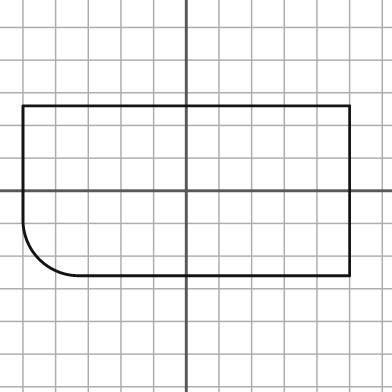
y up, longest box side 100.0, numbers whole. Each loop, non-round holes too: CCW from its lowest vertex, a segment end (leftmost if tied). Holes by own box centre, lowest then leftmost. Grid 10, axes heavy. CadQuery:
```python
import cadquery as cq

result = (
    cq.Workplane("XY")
    .moveTo(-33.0, -26.0)
    .lineTo(50.0, -26.0)
    .lineTo(50.0, 26.0)
    .lineTo(-50.0, 26.0)
    .lineTo(-50.0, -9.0)
    .threePointArc((-45.0, -21.0), (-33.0, -26.0))
    .close()
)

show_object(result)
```